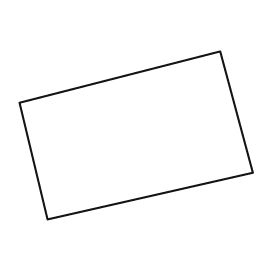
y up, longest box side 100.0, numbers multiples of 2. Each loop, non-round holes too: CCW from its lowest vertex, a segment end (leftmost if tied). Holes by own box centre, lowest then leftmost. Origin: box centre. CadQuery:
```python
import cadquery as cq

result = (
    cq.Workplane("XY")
    .moveTo(-38.0, -36.0)
    .lineTo(50.0, -16.0)
    .lineTo(36.0, 36.0)
    .lineTo(-50.0, 14.0)
    .close()
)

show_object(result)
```